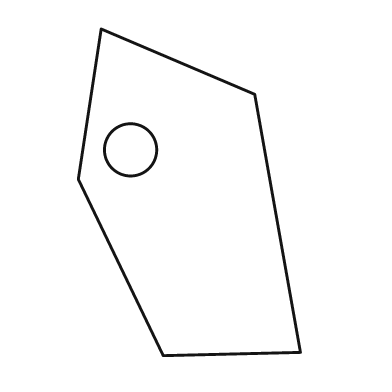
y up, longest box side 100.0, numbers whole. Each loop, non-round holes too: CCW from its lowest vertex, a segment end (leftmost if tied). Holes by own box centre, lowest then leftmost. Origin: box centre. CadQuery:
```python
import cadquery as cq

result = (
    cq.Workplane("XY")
    .moveTo(-8.0, -50.0)
    .lineTo(34.0, -49.0)
    .lineTo(20.0, 30.0)
    .lineTo(-27.0, 50.0)
    .lineTo(-34.0, 4.0)
    .close()
    .moveTo(-18.0, 13.0)
    .circle(8.0)
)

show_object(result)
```